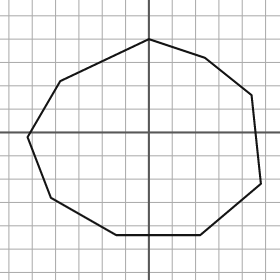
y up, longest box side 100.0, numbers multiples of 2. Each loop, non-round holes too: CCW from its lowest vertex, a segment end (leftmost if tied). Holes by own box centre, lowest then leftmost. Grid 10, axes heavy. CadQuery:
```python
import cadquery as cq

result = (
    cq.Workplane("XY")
    .moveTo(-14.0, -44.0)
    .lineTo(22.0, -44.0)
    .lineTo(48.0, -22.0)
    .lineTo(44.0, 16.0)
    .lineTo(24.0, 32.0)
    .lineTo(0.0, 40.0)
    .lineTo(-38.0, 22.0)
    .lineTo(-52.0, -2.0)
    .lineTo(-42.0, -28.0)
    .close()
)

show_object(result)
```